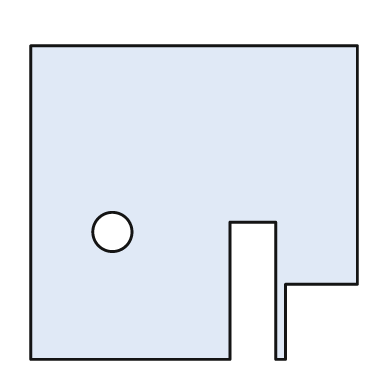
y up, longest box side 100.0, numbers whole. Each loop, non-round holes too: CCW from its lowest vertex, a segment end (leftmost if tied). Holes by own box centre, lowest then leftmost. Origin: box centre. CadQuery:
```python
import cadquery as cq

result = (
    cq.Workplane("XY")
    .moveTo(-50.0, -48.0)
    .lineTo(11.0, -48.0)
    .lineTo(11.0, -6.0)
    .lineTo(25.0, -6.0)
    .lineTo(25.0, -48.0)
    .lineTo(28.0, -48.0)
    .lineTo(28.0, -25.0)
    .lineTo(50.0, -25.0)
    .lineTo(50.0, 48.0)
    .lineTo(-50.0, 48.0)
    .close()
    .moveTo(-25.0, -9.0)
    .circle(6.0)
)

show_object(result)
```